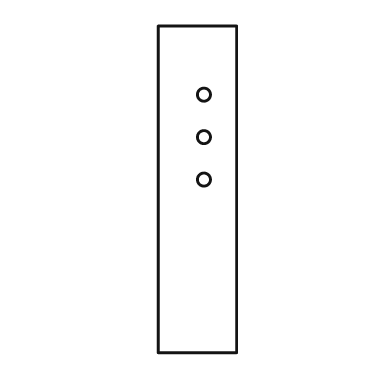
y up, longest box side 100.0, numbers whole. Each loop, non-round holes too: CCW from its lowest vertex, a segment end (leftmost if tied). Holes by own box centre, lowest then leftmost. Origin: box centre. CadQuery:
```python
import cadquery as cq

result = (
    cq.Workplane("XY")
    .moveTo(-12.0, -50.0)
    .lineTo(12.0, -50.0)
    .lineTo(12.0, 50.0)
    .lineTo(-12.0, 50.0)
    .close()
    .moveTo(2.0, 3.0)
    .circle(2.0)
    .moveTo(2.0, 16.0)
    .circle(2.0)
    .moveTo(2.0, 29.0)
    .circle(2.0)
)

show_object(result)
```